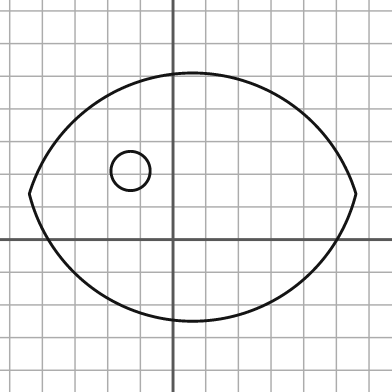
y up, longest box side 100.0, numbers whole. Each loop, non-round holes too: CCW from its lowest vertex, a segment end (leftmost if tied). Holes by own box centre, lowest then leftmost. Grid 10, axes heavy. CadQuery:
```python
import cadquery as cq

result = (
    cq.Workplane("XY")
    .moveTo(-44.0, 14.0)
    .threePointArc((6.0, -25.0), (56.0, 14.0))
    .threePointArc((6.0, 51.0), (-44.0, 14.0))
    .close()
    .moveTo(-13.0, 21.0)
    .circle(6.0)
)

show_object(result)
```